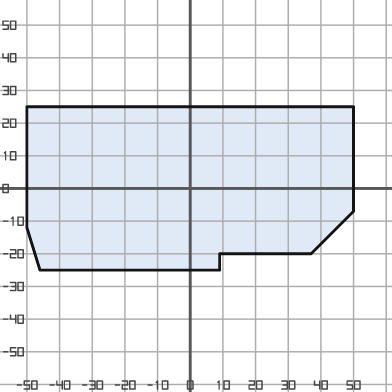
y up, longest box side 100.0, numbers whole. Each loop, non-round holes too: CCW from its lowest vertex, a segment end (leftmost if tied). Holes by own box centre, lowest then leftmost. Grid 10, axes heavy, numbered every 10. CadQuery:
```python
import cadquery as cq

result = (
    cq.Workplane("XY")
    .moveTo(-46.0, -25.0)
    .lineTo(9.0, -25.0)
    .lineTo(9.0, -20.0)
    .lineTo(37.0, -20.0)
    .lineTo(50.0, -7.0)
    .lineTo(50.0, 25.0)
    .lineTo(-50.0, 25.0)
    .lineTo(-50.0, -12.0)
    .close()
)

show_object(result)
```